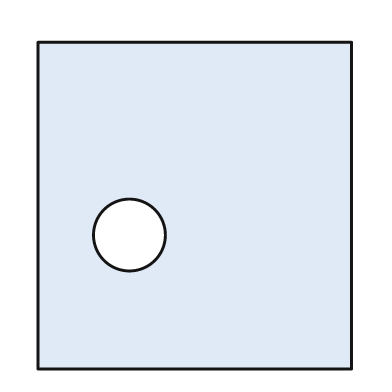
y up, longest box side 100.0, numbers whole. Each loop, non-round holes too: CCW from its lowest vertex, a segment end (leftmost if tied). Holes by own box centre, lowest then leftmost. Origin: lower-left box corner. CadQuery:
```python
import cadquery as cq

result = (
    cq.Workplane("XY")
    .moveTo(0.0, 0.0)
    .lineTo(96.0, 0.0)
    .lineTo(96.0, 100.0)
    .lineTo(0.0, 100.0)
    .close()
    .moveTo(28.0, 41.0)
    .circle(11.0)
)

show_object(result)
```